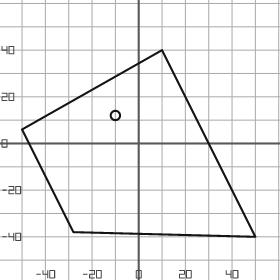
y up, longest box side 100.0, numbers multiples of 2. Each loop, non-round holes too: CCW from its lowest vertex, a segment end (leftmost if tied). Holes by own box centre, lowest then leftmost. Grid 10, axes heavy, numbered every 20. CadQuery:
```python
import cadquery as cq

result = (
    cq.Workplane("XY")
    .moveTo(50.0, -40.0)
    .lineTo(10.0, 40.0)
    .lineTo(-50.0, 6.0)
    .lineTo(-28.0, -38.0)
    .close()
    .moveTo(-10.0, 12.0)
    .circle(2.0)
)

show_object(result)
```